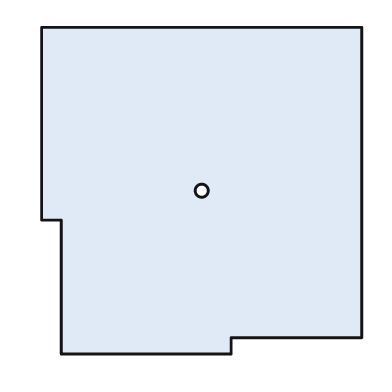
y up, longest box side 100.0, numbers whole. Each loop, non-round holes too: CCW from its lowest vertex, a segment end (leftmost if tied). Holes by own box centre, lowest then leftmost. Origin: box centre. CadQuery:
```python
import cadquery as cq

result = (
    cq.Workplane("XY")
    .moveTo(-43.0, -50.0)
    .lineTo(9.0, -50.0)
    .lineTo(9.0, -45.0)
    .lineTo(49.0, -45.0)
    .lineTo(49.0, 50.0)
    .lineTo(-49.0, 50.0)
    .lineTo(-49.0, -9.0)
    .lineTo(-43.0, -9.0)
    .close()
    .moveTo(0.0, 0.0)
    .circle(2.0)
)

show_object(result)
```